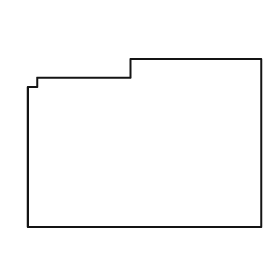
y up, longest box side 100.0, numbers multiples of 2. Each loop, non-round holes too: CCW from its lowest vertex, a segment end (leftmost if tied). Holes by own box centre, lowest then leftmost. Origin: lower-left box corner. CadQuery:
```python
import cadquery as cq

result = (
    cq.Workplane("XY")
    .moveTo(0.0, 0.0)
    .lineTo(100.0, 0.0)
    .lineTo(100.0, 72.0)
    .lineTo(44.0, 72.0)
    .lineTo(44.0, 64.0)
    .lineTo(4.0, 64.0)
    .lineTo(4.0, 60.0)
    .lineTo(0.0, 60.0)
    .close()
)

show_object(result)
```